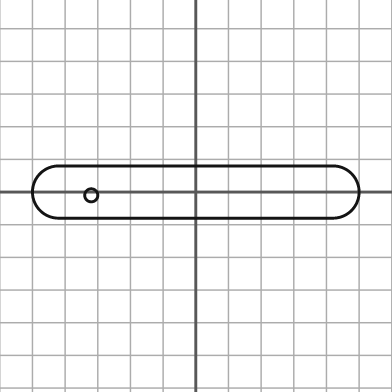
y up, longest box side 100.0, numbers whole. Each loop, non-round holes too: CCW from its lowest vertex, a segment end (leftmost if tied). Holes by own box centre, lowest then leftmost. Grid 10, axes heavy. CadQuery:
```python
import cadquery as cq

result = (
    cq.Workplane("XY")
    .moveTo(-42.0, -8.0)
    .lineTo(42.0, -8.0)
    .threePointArc((50.0, 0.0), (42.0, 8.0))
    .lineTo(-42.0, 8.0)
    .threePointArc((-50.0, 0.0), (-42.0, -8.0))
    .close()
    .moveTo(-32.0, -1.0)
    .circle(2.0)
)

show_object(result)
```